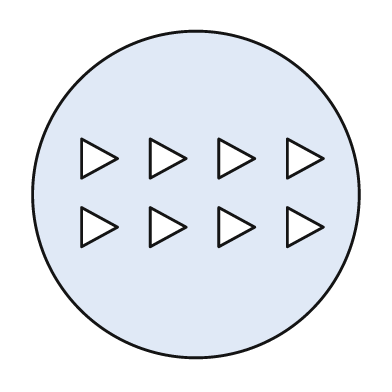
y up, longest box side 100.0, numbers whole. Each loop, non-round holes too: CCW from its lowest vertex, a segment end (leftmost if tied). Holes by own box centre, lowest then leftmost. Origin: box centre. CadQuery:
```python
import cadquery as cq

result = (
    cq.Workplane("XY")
    .moveTo(0.0, 0.0)
    .circle(50.0)
    .moveTo(-35.0, -16.0)
    .lineTo(-24.0, -10.0)
    .lineTo(-35.0, -4.0)
    .close()
    .moveTo(-14.0, -16.0)
    .lineTo(-3.0, -10.0)
    .lineTo(-14.0, -4.0)
    .close()
    .moveTo(7.0, -16.0)
    .lineTo(18.0, -10.0)
    .lineTo(7.0, -4.0)
    .close()
    .moveTo(28.0, -16.0)
    .lineTo(39.0, -10.0)
    .lineTo(28.0, -4.0)
    .close()
    .moveTo(-35.0, 5.0)
    .lineTo(-24.0, 11.0)
    .lineTo(-35.0, 17.0)
    .close()
    .moveTo(-14.0, 5.0)
    .lineTo(-3.0, 11.0)
    .lineTo(-14.0, 17.0)
    .close()
    .moveTo(7.0, 5.0)
    .lineTo(18.0, 11.0)
    .lineTo(7.0, 17.0)
    .close()
    .moveTo(28.0, 5.0)
    .lineTo(39.0, 11.0)
    .lineTo(28.0, 17.0)
    .close()
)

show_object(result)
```